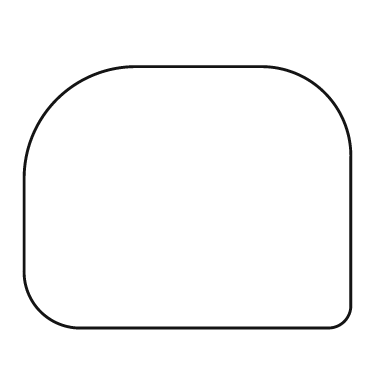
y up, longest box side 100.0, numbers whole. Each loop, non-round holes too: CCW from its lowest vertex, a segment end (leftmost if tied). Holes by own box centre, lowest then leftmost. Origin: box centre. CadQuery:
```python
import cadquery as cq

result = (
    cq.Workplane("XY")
    .moveTo(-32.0, -40.0)
    .lineTo(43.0, -40.0)
    .threePointArc((48.0, -38.0), (50.0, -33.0))
    .lineTo(50.0, 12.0)
    .threePointArc((42.0, 32.0), (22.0, 40.0))
    .lineTo(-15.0, 40.0)
    .threePointArc((-40.0, 30.0), (-50.0, 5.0))
    .lineTo(-50.0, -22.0)
    .threePointArc((-45.0, -35.0), (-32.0, -40.0))
    .close()
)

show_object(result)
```